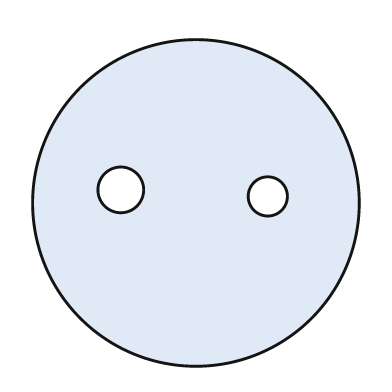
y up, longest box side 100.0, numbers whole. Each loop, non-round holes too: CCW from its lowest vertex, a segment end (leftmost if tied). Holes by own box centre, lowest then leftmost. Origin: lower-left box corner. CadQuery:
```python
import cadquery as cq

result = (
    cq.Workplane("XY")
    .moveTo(50.0, 50.0)
    .circle(50.0)
    .moveTo(72.0, 52.0)
    .circle(6.0)
    .moveTo(27.0, 54.0)
    .circle(7.0)
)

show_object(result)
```